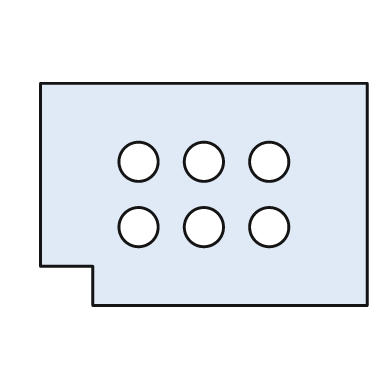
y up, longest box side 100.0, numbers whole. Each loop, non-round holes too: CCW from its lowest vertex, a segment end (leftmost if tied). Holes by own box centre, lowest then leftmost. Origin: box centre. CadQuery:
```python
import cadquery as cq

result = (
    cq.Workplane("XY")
    .moveTo(-34.0, -34.0)
    .lineTo(50.0, -34.0)
    .lineTo(50.0, 34.0)
    .lineTo(-50.0, 34.0)
    .lineTo(-50.0, -22.0)
    .lineTo(-34.0, -22.0)
    .close()
    .moveTo(-20.0, -10.0)
    .circle(6.0)
    .moveTo(0.0, -10.0)
    .circle(6.0)
    .moveTo(20.0, -10.0)
    .circle(6.0)
    .moveTo(-20.0, 10.0)
    .circle(6.0)
    .moveTo(0.0, 10.0)
    .circle(6.0)
    .moveTo(20.0, 10.0)
    .circle(6.0)
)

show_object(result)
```